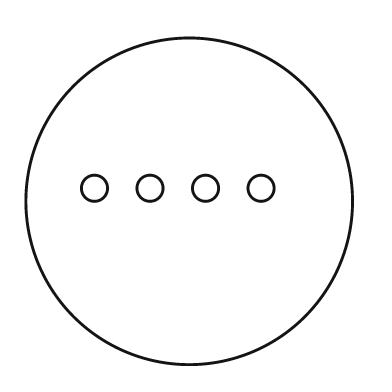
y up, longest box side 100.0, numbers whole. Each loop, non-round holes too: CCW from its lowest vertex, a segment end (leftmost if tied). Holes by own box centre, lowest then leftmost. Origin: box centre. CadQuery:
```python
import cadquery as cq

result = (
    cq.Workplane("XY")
    .moveTo(0.0, 0.0)
    .circle(50.0)
    .moveTo(-29.0, 4.0)
    .circle(4.0)
    .moveTo(-12.0, 4.0)
    .circle(4.0)
    .moveTo(5.0, 4.0)
    .circle(4.0)
    .moveTo(22.0, 4.0)
    .circle(4.0)
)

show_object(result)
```